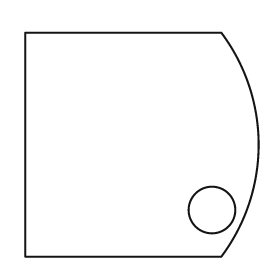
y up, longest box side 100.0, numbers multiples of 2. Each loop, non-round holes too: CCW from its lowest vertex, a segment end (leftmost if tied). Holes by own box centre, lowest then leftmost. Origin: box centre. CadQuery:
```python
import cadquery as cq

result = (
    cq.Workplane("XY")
    .moveTo(-50.0, -48.0)
    .lineTo(34.0, -48.0)
    .threePointArc((50.0, 0.0), (34.0, 48.0))
    .lineTo(-50.0, 48.0)
    .close()
    .moveTo(30.0, -28.0)
    .circle(10.0)
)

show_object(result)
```